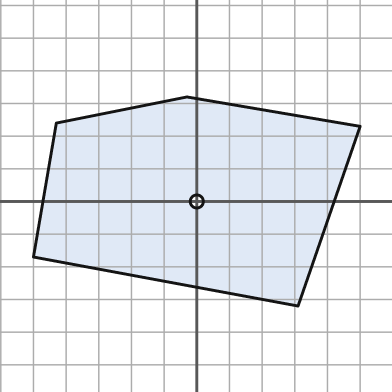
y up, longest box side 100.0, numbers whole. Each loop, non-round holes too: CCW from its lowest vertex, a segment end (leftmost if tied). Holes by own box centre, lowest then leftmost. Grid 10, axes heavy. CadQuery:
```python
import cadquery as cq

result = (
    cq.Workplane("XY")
    .moveTo(31.0, -32.0)
    .lineTo(50.0, 23.0)
    .lineTo(-3.0, 32.0)
    .lineTo(-43.0, 24.0)
    .lineTo(-50.0, -17.0)
    .close()
    .moveTo(0.0, 0.0)
    .circle(2.0)
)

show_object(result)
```